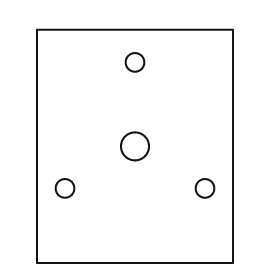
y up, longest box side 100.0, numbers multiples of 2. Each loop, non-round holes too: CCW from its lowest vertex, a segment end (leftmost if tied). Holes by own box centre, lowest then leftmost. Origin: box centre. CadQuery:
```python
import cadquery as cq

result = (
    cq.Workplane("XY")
    .moveTo(-42.0, -50.0)
    .lineTo(42.0, -50.0)
    .lineTo(42.0, 50.0)
    .lineTo(-42.0, 50.0)
    .close()
    .moveTo(-30.0, -18.0)
    .circle(4.0)
    .moveTo(30.0, -18.0)
    .circle(4.0)
    .moveTo(0.0, 0.0)
    .circle(6.0)
    .moveTo(0.0, 36.0)
    .circle(4.0)
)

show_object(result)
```